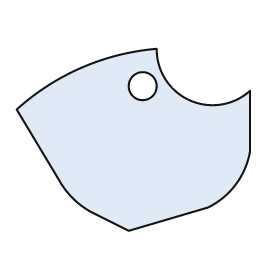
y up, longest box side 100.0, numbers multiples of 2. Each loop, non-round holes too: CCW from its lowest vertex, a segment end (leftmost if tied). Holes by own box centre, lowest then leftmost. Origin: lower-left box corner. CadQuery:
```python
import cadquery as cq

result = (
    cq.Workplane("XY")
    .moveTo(48.0, 0.0)
    .lineTo(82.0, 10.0)
    .threePointArc((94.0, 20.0), (100.0, 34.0))
    .lineTo(100.0, 60.0)
    .threePointArc((74.0, 56.0), (60.0, 78.0))
    .threePointArc((28.0, 70.0), (0.0, 52.0))
    .lineTo(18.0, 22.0)
    .threePointArc((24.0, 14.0), (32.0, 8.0))
    .close()
    .moveTo(54.0, 62.0)
    .circle(6.0)
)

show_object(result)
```